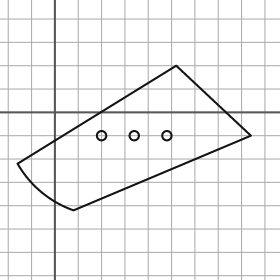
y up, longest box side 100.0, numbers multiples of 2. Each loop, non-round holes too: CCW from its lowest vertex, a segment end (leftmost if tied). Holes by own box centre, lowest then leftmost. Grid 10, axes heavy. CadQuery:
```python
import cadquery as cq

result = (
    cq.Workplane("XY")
    .moveTo(8.0, -42.0)
    .lineTo(84.0, -10.0)
    .lineTo(52.0, 20.0)
    .lineTo(-16.0, -22.0)
    .threePointArc((-6.0, -34.0), (8.0, -42.0))
    .close()
    .moveTo(20.0, -10.0)
    .circle(2.0)
    .moveTo(34.0, -10.0)
    .circle(2.0)
    .moveTo(48.0, -10.0)
    .circle(2.0)
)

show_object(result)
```